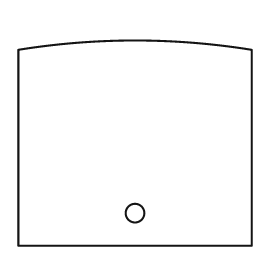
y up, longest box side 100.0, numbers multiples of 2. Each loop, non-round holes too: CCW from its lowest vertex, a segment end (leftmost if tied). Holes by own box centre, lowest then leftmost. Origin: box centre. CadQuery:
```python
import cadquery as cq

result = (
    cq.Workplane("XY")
    .moveTo(-50.0, -44.0)
    .lineTo(50.0, -44.0)
    .lineTo(50.0, 40.0)
    .threePointArc((0.0, 44.0), (-50.0, 40.0))
    .close()
    .moveTo(0.0, -30.0)
    .circle(4.0)
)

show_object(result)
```